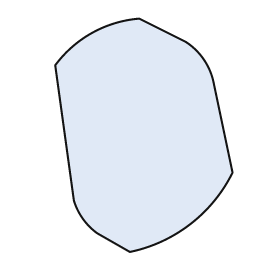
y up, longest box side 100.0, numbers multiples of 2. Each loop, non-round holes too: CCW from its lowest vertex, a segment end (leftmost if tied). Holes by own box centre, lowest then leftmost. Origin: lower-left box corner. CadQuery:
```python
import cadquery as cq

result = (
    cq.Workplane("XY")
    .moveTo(32.0, 0.0)
    .threePointArc((58.0, 12.0), (76.0, 34.0))
    .lineTo(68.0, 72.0)
    .threePointArc((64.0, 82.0), (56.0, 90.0))
    .lineTo(36.0, 100.0)
    .threePointArc((16.0, 94.0), (0.0, 80.0))
    .lineTo(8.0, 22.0)
    .threePointArc((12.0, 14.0), (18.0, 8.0))
    .close()
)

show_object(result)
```